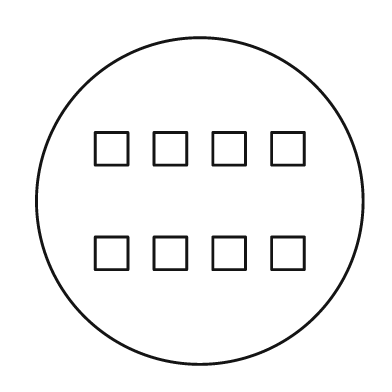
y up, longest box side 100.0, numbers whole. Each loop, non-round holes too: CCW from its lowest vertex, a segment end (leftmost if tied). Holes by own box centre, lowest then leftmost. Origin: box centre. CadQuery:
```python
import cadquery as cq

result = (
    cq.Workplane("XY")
    .moveTo(0.0, 0.0)
    .circle(50.0)
    .moveTo(-32.0, -21.0)
    .lineTo(-22.0, -21.0)
    .lineTo(-22.0, -11.0)
    .lineTo(-32.0, -11.0)
    .close()
    .moveTo(-14.0, -21.0)
    .lineTo(-4.0, -21.0)
    .lineTo(-4.0, -11.0)
    .lineTo(-14.0, -11.0)
    .close()
    .moveTo(4.0, -21.0)
    .lineTo(14.0, -21.0)
    .lineTo(14.0, -11.0)
    .lineTo(4.0, -11.0)
    .close()
    .moveTo(22.0, -21.0)
    .lineTo(32.0, -21.0)
    .lineTo(32.0, -11.0)
    .lineTo(22.0, -11.0)
    .close()
    .moveTo(-32.0, 11.0)
    .lineTo(-22.0, 11.0)
    .lineTo(-22.0, 21.0)
    .lineTo(-32.0, 21.0)
    .close()
    .moveTo(-14.0, 11.0)
    .lineTo(-4.0, 11.0)
    .lineTo(-4.0, 21.0)
    .lineTo(-14.0, 21.0)
    .close()
    .moveTo(4.0, 11.0)
    .lineTo(14.0, 11.0)
    .lineTo(14.0, 21.0)
    .lineTo(4.0, 21.0)
    .close()
    .moveTo(22.0, 11.0)
    .lineTo(32.0, 11.0)
    .lineTo(32.0, 21.0)
    .lineTo(22.0, 21.0)
    .close()
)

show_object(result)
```